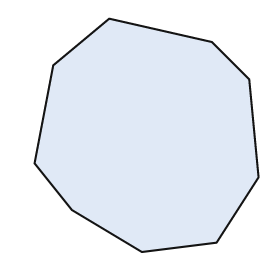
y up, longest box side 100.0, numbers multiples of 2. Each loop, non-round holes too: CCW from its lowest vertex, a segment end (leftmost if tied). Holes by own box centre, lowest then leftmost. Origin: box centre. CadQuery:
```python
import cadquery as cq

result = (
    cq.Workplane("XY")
    .moveTo(-2.0, -50.0)
    .lineTo(30.0, -46.0)
    .lineTo(48.0, -18.0)
    .lineTo(44.0, 24.0)
    .lineTo(28.0, 40.0)
    .lineTo(-16.0, 50.0)
    .lineTo(-40.0, 30.0)
    .lineTo(-48.0, -12.0)
    .lineTo(-32.0, -32.0)
    .close()
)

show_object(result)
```